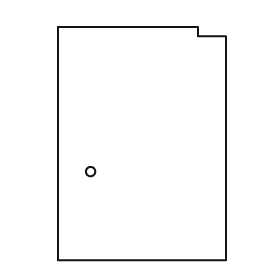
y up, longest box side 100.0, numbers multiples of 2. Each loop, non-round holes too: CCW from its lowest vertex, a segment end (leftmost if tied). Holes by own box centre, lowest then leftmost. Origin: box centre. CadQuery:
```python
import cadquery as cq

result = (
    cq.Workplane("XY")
    .moveTo(-36.0, -50.0)
    .lineTo(36.0, -50.0)
    .lineTo(36.0, 46.0)
    .lineTo(24.0, 46.0)
    .lineTo(24.0, 50.0)
    .lineTo(-36.0, 50.0)
    .close()
    .moveTo(-22.0, -12.0)
    .circle(2.0)
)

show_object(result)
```